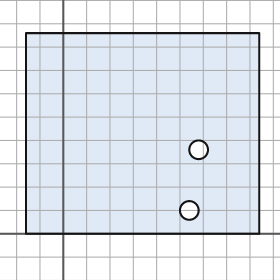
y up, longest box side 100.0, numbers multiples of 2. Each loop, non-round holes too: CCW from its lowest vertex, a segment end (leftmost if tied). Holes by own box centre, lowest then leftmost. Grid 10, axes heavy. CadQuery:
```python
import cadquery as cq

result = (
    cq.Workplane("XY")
    .moveTo(-16.0, 0.0)
    .lineTo(84.0, 0.0)
    .lineTo(84.0, 86.0)
    .lineTo(-16.0, 86.0)
    .close()
    .moveTo(54.0, 10.0)
    .circle(4.0)
    .moveTo(58.0, 36.0)
    .circle(4.0)
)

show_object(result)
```